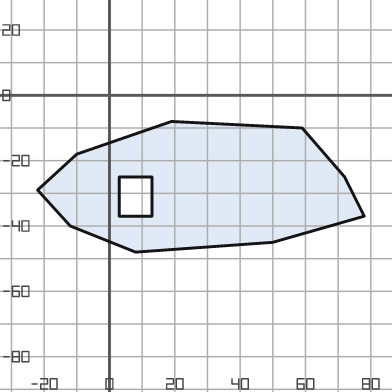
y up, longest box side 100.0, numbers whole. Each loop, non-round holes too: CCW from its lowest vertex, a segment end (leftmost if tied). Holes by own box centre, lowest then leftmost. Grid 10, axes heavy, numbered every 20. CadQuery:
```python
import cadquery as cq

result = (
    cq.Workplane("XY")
    .moveTo(8.0, -48.0)
    .lineTo(50.0, -45.0)
    .lineTo(78.0, -37.0)
    .lineTo(72.0, -25.0)
    .lineTo(59.0, -10.0)
    .lineTo(19.0, -8.0)
    .lineTo(-10.0, -18.0)
    .lineTo(-22.0, -29.0)
    .lineTo(-12.0, -40.0)
    .close()
    .moveTo(3.0, -37.0)
    .lineTo(13.0, -37.0)
    .lineTo(13.0, -25.0)
    .lineTo(3.0, -25.0)
    .close()
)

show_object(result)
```